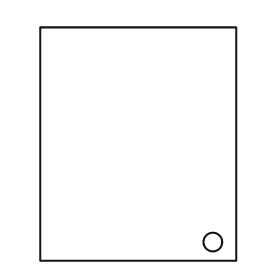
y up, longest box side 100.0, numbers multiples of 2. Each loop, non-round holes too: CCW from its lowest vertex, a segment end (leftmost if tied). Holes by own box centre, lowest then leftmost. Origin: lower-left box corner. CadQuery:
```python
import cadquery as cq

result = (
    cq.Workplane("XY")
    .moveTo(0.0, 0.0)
    .lineTo(84.0, 0.0)
    .lineTo(84.0, 100.0)
    .lineTo(0.0, 100.0)
    .close()
    .moveTo(74.0, 8.0)
    .circle(4.0)
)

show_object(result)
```